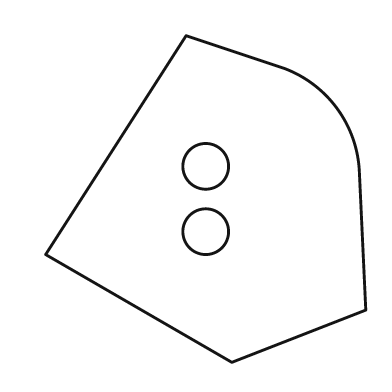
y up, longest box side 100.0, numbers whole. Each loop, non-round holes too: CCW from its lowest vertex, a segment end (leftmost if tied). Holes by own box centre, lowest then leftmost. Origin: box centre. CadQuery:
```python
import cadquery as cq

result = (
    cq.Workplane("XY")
    .moveTo(8.0, -50.0)
    .lineTo(49.0, -34.0)
    .lineTo(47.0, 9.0)
    .threePointArc((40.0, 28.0), (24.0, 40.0))
    .lineTo(-6.0, 50.0)
    .lineTo(-49.0, -17.0)
    .close()
    .moveTo(0.0, -10.0)
    .circle(7.0)
    .moveTo(0.0, 10.0)
    .circle(7.0)
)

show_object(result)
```